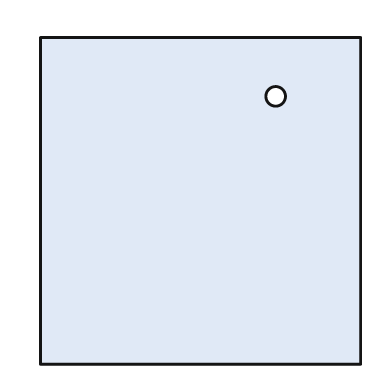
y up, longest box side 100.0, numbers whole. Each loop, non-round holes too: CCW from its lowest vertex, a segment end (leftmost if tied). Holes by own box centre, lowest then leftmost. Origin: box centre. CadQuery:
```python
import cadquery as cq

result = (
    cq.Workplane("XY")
    .moveTo(-49.0, -50.0)
    .lineTo(49.0, -50.0)
    .lineTo(49.0, 50.0)
    .lineTo(-49.0, 50.0)
    .close()
    .moveTo(23.0, 32.0)
    .circle(3.0)
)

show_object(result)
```